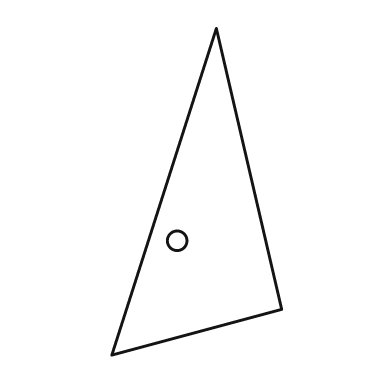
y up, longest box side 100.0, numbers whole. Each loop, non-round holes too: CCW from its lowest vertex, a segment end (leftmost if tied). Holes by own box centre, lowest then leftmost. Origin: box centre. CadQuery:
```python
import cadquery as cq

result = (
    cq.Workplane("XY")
    .moveTo(-26.0, -50.0)
    .lineTo(26.0, -36.0)
    .lineTo(6.0, 50.0)
    .close()
    .moveTo(-6.0, -15.0)
    .circle(3.0)
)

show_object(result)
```